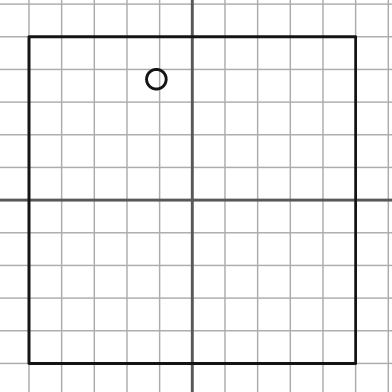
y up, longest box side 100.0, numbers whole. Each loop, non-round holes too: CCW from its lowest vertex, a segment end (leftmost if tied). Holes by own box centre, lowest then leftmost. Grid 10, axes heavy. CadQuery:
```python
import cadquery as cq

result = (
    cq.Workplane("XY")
    .moveTo(-50.0, -50.0)
    .lineTo(50.0, -50.0)
    .lineTo(50.0, 50.0)
    .lineTo(-50.0, 50.0)
    .close()
    .moveTo(-11.0, 37.0)
    .circle(3.0)
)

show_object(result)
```